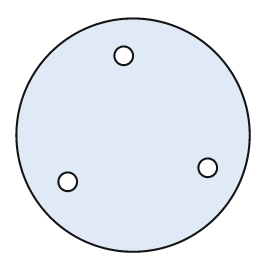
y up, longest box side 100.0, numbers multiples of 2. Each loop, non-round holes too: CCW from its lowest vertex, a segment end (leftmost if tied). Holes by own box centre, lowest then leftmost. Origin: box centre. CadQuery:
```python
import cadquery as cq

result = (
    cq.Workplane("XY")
    .moveTo(0.0, 0.0)
    .circle(50.0)
    .moveTo(-28.0, -20.0)
    .circle(4.0)
    .moveTo(32.0, -14.0)
    .circle(4.0)
    .moveTo(-4.0, 34.0)
    .circle(4.0)
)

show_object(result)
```